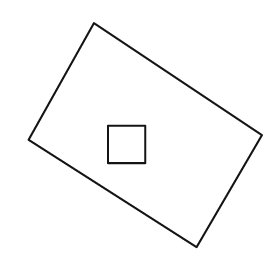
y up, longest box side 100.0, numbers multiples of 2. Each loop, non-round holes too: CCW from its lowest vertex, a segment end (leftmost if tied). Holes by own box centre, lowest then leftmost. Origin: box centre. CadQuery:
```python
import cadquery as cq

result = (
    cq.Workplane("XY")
    .moveTo(22.0, -48.0)
    .lineTo(50.0, 0.0)
    .lineTo(-22.0, 48.0)
    .lineTo(-50.0, -2.0)
    .close()
    .moveTo(-16.0, -12.0)
    .lineTo(0.0, -12.0)
    .lineTo(0.0, 4.0)
    .lineTo(-16.0, 4.0)
    .close()
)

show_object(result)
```